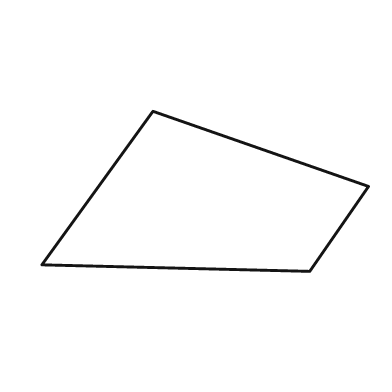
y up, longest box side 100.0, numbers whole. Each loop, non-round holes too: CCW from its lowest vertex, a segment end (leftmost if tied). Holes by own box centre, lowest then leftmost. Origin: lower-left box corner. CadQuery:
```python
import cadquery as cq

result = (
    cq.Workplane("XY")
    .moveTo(82.0, 0.0)
    .lineTo(100.0, 26.0)
    .lineTo(34.0, 49.0)
    .lineTo(0.0, 2.0)
    .close()
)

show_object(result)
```